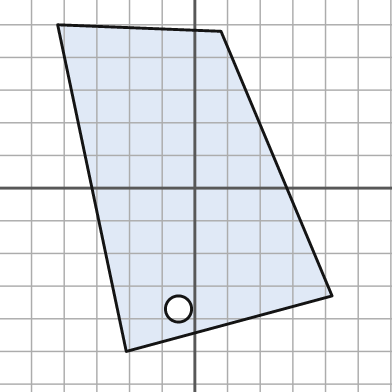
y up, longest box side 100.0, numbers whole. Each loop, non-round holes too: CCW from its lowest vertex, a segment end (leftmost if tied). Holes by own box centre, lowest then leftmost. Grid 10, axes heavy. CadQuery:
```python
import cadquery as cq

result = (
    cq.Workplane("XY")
    .moveTo(-21.0, -50.0)
    .lineTo(42.0, -33.0)
    .lineTo(8.0, 48.0)
    .lineTo(-42.0, 50.0)
    .close()
    .moveTo(-5.0, -37.0)
    .circle(4.0)
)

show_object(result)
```